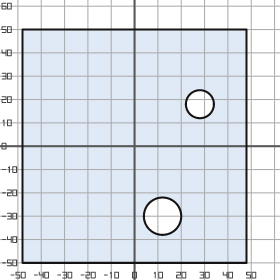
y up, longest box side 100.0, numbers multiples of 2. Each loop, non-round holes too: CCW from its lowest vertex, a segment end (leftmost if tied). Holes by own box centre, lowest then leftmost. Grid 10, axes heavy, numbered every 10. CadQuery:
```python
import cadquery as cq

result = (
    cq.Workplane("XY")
    .moveTo(-48.0, -50.0)
    .lineTo(48.0, -50.0)
    .lineTo(48.0, 50.0)
    .lineTo(-48.0, 50.0)
    .close()
    .moveTo(12.0, -30.0)
    .circle(8.0)
    .moveTo(28.0, 18.0)
    .circle(6.0)
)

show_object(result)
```